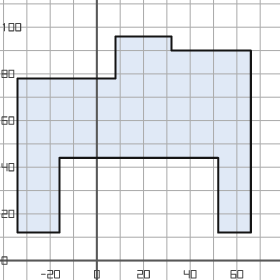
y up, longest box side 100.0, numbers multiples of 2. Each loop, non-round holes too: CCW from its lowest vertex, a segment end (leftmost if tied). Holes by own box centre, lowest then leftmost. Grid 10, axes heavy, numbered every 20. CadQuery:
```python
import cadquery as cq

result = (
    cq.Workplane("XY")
    .moveTo(-34.0, 12.0)
    .lineTo(-16.0, 12.0)
    .lineTo(-16.0, 44.0)
    .lineTo(52.0, 44.0)
    .lineTo(52.0, 12.0)
    .lineTo(66.0, 12.0)
    .lineTo(66.0, 90.0)
    .lineTo(32.0, 90.0)
    .lineTo(32.0, 96.0)
    .lineTo(8.0, 96.0)
    .lineTo(8.0, 78.0)
    .lineTo(-34.0, 78.0)
    .close()
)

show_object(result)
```